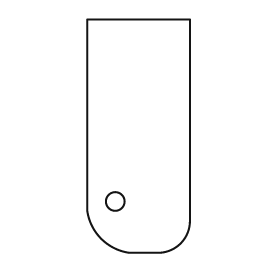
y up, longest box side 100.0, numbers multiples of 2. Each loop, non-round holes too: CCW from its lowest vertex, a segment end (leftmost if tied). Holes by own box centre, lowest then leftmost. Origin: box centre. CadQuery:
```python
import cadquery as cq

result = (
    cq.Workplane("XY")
    .moveTo(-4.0, -50.0)
    .lineTo(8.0, -50.0)
    .threePointArc((18.0, -46.0), (22.0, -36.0))
    .lineTo(22.0, 50.0)
    .lineTo(-22.0, 50.0)
    .lineTo(-22.0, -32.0)
    .threePointArc((-16.0, -44.0), (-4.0, -50.0))
    .close()
    .moveTo(-10.0, -28.0)
    .circle(4.0)
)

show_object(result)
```